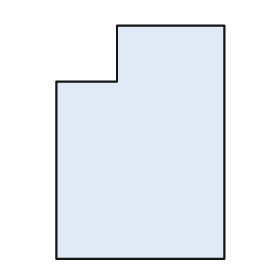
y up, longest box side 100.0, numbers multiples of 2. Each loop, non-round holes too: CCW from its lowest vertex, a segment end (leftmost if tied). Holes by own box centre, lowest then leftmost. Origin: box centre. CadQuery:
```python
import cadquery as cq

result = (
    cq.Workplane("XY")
    .moveTo(-36.0, -50.0)
    .lineTo(36.0, -50.0)
    .lineTo(36.0, 50.0)
    .lineTo(-10.0, 50.0)
    .lineTo(-10.0, 26.0)
    .lineTo(-36.0, 26.0)
    .close()
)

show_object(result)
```